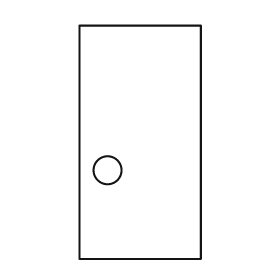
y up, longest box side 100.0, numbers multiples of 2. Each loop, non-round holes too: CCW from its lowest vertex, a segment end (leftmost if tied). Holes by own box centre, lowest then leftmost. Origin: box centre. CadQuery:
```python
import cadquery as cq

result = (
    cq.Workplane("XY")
    .moveTo(-26.0, -50.0)
    .lineTo(26.0, -50.0)
    .lineTo(26.0, 50.0)
    .lineTo(-26.0, 50.0)
    .close()
    .moveTo(-14.0, -12.0)
    .circle(6.0)
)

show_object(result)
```